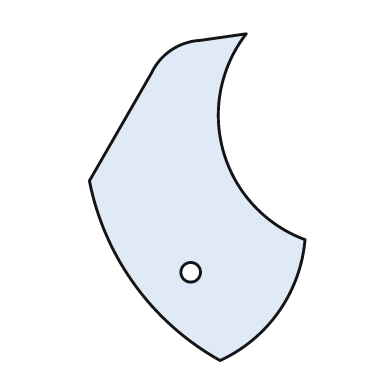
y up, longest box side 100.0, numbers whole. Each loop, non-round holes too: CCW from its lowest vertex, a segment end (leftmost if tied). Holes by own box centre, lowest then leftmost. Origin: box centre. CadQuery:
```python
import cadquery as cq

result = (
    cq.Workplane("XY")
    .moveTo(7.0, -50.0)
    .threePointArc((25.0, -35.0), (33.0, -13.0))
    .threePointArc((8.0, 14.0), (15.0, 50.0))
    .lineTo(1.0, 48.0)
    .threePointArc((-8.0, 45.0), (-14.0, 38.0))
    .lineTo(-33.0, 5.0)
    .threePointArc((-19.0, -27.0), (7.0, -50.0))
    .close()
    .moveTo(-2.0, -23.0)
    .circle(3.0)
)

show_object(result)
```